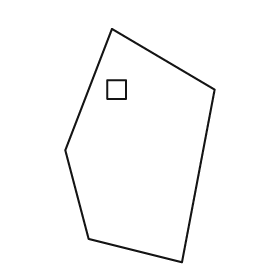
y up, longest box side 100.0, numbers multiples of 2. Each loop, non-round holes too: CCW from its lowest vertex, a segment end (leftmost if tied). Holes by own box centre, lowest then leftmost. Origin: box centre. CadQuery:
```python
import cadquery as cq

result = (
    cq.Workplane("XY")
    .moveTo(18.0, -50.0)
    .lineTo(32.0, 24.0)
    .lineTo(-12.0, 50.0)
    .lineTo(-32.0, -2.0)
    .lineTo(-22.0, -40.0)
    .close()
    .moveTo(-14.0, 20.0)
    .lineTo(-6.0, 20.0)
    .lineTo(-6.0, 28.0)
    .lineTo(-14.0, 28.0)
    .close()
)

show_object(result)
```